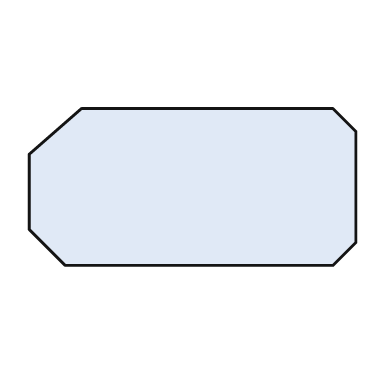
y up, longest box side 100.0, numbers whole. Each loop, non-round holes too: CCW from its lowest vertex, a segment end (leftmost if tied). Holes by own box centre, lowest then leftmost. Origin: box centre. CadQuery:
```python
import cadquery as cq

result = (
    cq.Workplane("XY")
    .moveTo(-39.0, -24.0)
    .lineTo(43.0, -24.0)
    .lineTo(50.0, -17.0)
    .lineTo(50.0, 17.0)
    .lineTo(43.0, 24.0)
    .lineTo(-34.0, 24.0)
    .lineTo(-50.0, 10.0)
    .lineTo(-50.0, -13.0)
    .close()
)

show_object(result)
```